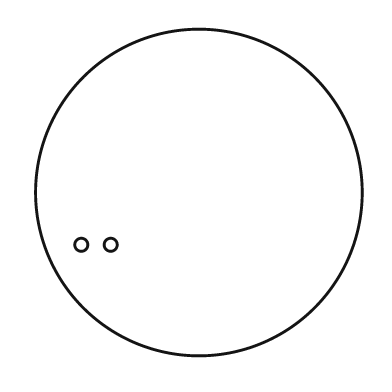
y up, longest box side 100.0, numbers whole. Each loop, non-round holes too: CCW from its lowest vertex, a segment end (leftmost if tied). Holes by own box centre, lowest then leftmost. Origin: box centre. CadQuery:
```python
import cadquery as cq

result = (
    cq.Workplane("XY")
    .moveTo(0.0, 0.0)
    .circle(50.0)
    .moveTo(-36.0, -16.0)
    .circle(2.0)
    .moveTo(-27.0, -16.0)
    .circle(2.0)
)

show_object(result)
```